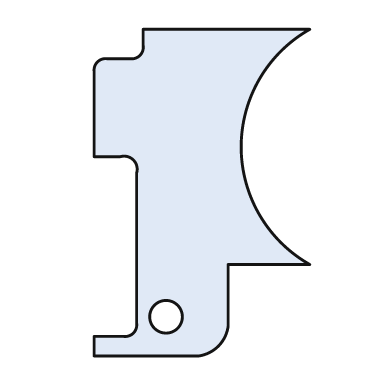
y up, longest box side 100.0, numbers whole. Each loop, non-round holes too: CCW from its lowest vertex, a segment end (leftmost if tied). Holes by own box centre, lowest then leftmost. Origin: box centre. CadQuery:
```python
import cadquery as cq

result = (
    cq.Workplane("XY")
    .moveTo(-33.0, -50.0)
    .lineTo(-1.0, -50.0)
    .threePointArc((5.0, -47.0), (8.0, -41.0))
    .lineTo(8.0, -22.0)
    .lineTo(33.0, -22.0)
    .threePointArc((12.0, 14.0), (33.0, 50.0))
    .lineTo(-18.0, 50.0)
    .lineTo(-18.0, 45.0)
    .threePointArc((-19.0, 42.0), (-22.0, 41.0))
    .lineTo(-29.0, 41.0)
    .threePointArc((-32.0, 40.0), (-33.0, 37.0))
    .lineTo(-33.0, 11.0)
    .lineTo(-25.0, 11.0)
    .threePointArc((-21.0, 10.0), (-20.0, 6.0))
    .lineTo(-20.0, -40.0)
    .threePointArc((-21.0, -43.0), (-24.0, -44.0))
    .lineTo(-33.0, -44.0)
    .close()
    .moveTo(-11.0, -38.0)
    .circle(5.0)
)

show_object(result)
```